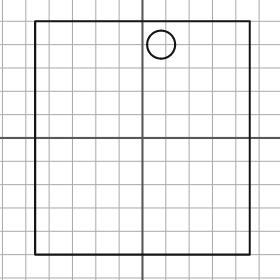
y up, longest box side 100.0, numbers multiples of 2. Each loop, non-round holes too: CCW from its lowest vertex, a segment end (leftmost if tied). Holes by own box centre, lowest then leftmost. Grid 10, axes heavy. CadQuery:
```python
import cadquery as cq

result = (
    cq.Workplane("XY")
    .moveTo(-46.0, -50.0)
    .lineTo(46.0, -50.0)
    .lineTo(46.0, 50.0)
    .lineTo(-46.0, 50.0)
    .close()
    .moveTo(8.0, 40.0)
    .circle(6.0)
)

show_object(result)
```